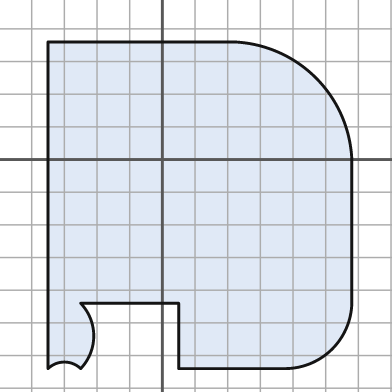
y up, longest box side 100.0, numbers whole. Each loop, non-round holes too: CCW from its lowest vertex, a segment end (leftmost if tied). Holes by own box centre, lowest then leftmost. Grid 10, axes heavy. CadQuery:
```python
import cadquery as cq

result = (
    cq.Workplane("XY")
    .moveTo(-35.0, -64.0)
    .threePointArc((-30.0, -62.0), (-25.0, -64.0))
    .threePointArc((-21.0, -54.0), (-25.0, -44.0))
    .lineTo(5.0, -44.0)
    .lineTo(5.0, -64.0)
    .lineTo(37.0, -64.0)
    .threePointArc((52.0, -58.0), (58.0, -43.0))
    .lineTo(58.0, 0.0)
    .threePointArc((47.0, 25.0), (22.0, 36.0))
    .lineTo(-35.0, 36.0)
    .close()
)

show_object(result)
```